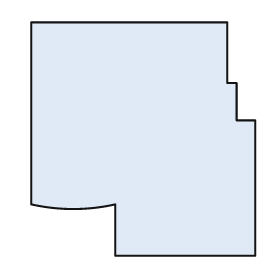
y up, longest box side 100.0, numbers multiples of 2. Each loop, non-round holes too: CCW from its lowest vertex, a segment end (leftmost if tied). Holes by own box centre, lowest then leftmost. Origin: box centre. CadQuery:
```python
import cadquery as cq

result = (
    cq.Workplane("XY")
    .moveTo(-12.0, -50.0)
    .lineTo(48.0, -50.0)
    .lineTo(48.0, 8.0)
    .lineTo(40.0, 8.0)
    .lineTo(40.0, 24.0)
    .lineTo(36.0, 24.0)
    .lineTo(36.0, 50.0)
    .lineTo(-48.0, 50.0)
    .lineTo(-48.0, -28.0)
    .threePointArc((-30.0, -30.0), (-12.0, -28.0))
    .close()
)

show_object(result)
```